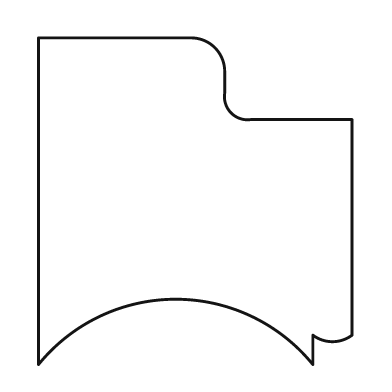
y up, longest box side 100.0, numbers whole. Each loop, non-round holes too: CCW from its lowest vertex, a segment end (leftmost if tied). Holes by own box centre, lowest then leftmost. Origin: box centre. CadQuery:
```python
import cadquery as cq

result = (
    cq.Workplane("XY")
    .moveTo(-48.0, -50.0)
    .threePointArc((-6.0, -30.0), (36.0, -50.0))
    .lineTo(36.0, -41.0)
    .threePointArc((42.0, -43.0), (48.0, -41.0))
    .lineTo(48.0, 25.0)
    .lineTo(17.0, 25.0)
    .threePointArc((11.0, 27.0), (9.0, 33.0))
    .lineTo(9.0, 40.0)
    .threePointArc((6.0, 47.0), (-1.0, 50.0))
    .lineTo(-48.0, 50.0)
    .close()
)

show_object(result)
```